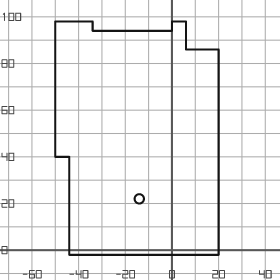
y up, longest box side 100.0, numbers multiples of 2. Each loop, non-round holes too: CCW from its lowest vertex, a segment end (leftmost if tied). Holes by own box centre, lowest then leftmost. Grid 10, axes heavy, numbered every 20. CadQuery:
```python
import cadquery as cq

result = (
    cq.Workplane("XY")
    .moveTo(-44.0, -2.0)
    .lineTo(20.0, -2.0)
    .lineTo(20.0, 86.0)
    .lineTo(6.0, 86.0)
    .lineTo(6.0, 98.0)
    .lineTo(0.0, 98.0)
    .lineTo(0.0, 94.0)
    .lineTo(-34.0, 94.0)
    .lineTo(-34.0, 98.0)
    .lineTo(-50.0, 98.0)
    .lineTo(-50.0, 40.0)
    .lineTo(-44.0, 40.0)
    .close()
    .moveTo(-14.0, 22.0)
    .circle(2.0)
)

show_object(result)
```